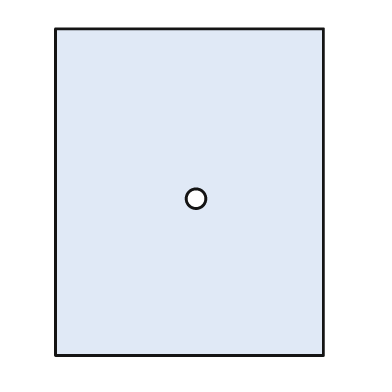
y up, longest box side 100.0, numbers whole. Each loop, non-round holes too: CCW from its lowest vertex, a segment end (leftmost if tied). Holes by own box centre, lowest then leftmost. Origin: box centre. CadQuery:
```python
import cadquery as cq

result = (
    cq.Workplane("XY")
    .moveTo(-41.0, -50.0)
    .lineTo(41.0, -50.0)
    .lineTo(41.0, 50.0)
    .lineTo(-41.0, 50.0)
    .close()
    .moveTo(2.0, -2.0)
    .circle(3.0)
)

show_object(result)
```